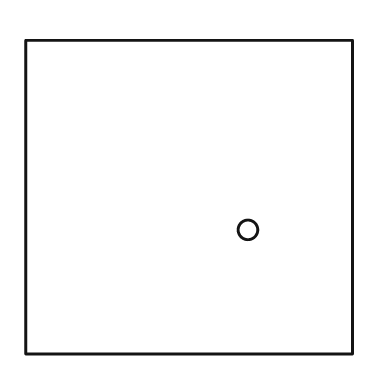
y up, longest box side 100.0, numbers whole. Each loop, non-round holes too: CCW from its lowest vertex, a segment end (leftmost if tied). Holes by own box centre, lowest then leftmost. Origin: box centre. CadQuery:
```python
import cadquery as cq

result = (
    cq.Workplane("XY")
    .moveTo(-50.0, -48.0)
    .lineTo(50.0, -48.0)
    .lineTo(50.0, 48.0)
    .lineTo(-50.0, 48.0)
    .close()
    .moveTo(18.0, -10.0)
    .circle(3.0)
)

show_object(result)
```